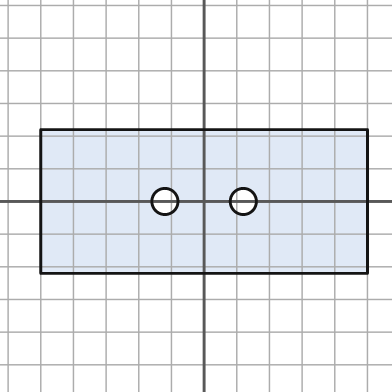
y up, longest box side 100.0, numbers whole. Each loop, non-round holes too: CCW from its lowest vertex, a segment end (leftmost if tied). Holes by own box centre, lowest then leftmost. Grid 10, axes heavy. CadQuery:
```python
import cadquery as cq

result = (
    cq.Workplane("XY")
    .moveTo(-50.0, -22.0)
    .lineTo(50.0, -22.0)
    .lineTo(50.0, 22.0)
    .lineTo(-50.0, 22.0)
    .close()
    .moveTo(-12.0, 0.0)
    .circle(4.0)
    .moveTo(12.0, 0.0)
    .circle(4.0)
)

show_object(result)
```